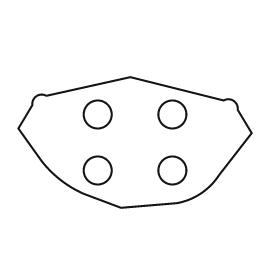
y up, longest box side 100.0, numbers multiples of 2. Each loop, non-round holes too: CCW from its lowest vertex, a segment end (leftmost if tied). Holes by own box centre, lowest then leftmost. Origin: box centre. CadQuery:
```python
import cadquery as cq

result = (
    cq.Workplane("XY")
    .moveTo(-6.0, -28.0)
    .lineTo(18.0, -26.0)
    .threePointArc((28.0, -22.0), (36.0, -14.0))
    .lineTo(50.0, 4.0)
    .lineTo(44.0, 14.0)
    .threePointArc((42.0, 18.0), (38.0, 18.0))
    .lineTo(-2.0, 28.0)
    .lineTo(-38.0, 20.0)
    .threePointArc((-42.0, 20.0), (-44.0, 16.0))
    .lineTo(-50.0, 6.0)
    .lineTo(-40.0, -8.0)
    .threePointArc((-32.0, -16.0), (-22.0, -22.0))
    .close()
    .moveTo(-16.0, -12.0)
    .circle(6.0)
    .moveTo(16.0, -12.0)
    .circle(6.0)
    .moveTo(-16.0, 12.0)
    .circle(6.0)
    .moveTo(16.0, 12.0)
    .circle(6.0)
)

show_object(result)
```